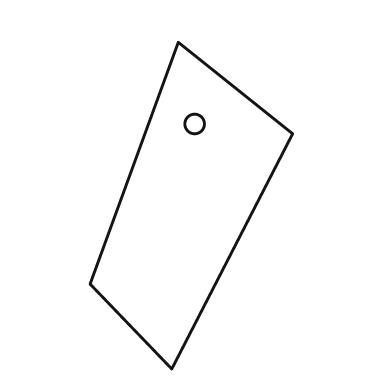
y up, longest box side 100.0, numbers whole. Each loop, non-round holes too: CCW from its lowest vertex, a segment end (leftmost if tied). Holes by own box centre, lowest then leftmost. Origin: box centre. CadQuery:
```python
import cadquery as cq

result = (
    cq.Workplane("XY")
    .moveTo(-6.0, -50.0)
    .lineTo(31.0, 22.0)
    .lineTo(-4.0, 50.0)
    .lineTo(-31.0, -24.0)
    .close()
    .moveTo(1.0, 25.0)
    .circle(3.0)
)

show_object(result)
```